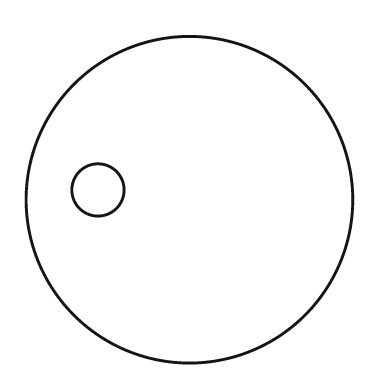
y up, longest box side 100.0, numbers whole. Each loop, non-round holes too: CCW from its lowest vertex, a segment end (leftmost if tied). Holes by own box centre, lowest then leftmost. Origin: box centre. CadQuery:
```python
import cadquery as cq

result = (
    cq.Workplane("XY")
    .moveTo(0.0, 0.0)
    .circle(50.0)
    .moveTo(-28.0, 3.0)
    .circle(8.0)
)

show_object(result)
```